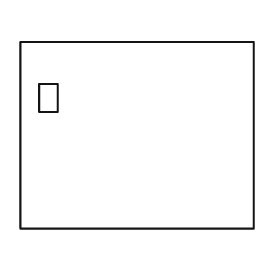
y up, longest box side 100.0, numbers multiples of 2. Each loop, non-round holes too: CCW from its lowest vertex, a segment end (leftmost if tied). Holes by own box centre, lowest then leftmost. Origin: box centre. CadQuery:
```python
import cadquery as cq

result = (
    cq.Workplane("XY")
    .moveTo(-50.0, -40.0)
    .lineTo(50.0, -40.0)
    .lineTo(50.0, 40.0)
    .lineTo(-50.0, 40.0)
    .close()
    .moveTo(-42.0, 10.0)
    .lineTo(-34.0, 10.0)
    .lineTo(-34.0, 22.0)
    .lineTo(-42.0, 22.0)
    .close()
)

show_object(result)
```